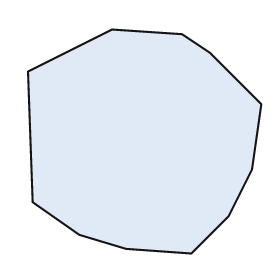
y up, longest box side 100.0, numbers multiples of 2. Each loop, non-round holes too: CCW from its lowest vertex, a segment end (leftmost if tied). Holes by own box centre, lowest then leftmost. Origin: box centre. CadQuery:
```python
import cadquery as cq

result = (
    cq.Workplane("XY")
    .moveTo(20.0, -48.0)
    .lineTo(36.0, -32.0)
    .lineTo(46.0, -12.0)
    .lineTo(50.0, 16.0)
    .lineTo(28.0, 38.0)
    .lineTo(16.0, 46.0)
    .lineTo(-14.0, 48.0)
    .lineTo(-50.0, 30.0)
    .lineTo(-48.0, -26.0)
    .lineTo(-28.0, -40.0)
    .lineTo(-8.0, -46.0)
    .close()
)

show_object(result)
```